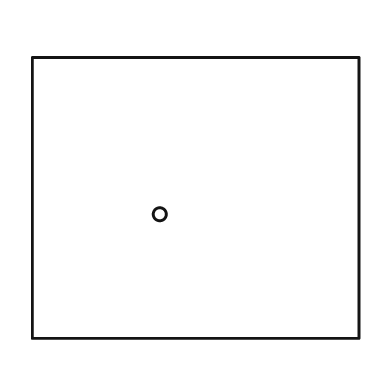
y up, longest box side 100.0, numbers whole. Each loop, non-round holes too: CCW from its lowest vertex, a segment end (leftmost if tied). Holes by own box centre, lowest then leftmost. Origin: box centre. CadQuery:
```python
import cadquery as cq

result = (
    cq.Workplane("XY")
    .moveTo(-50.0, -43.0)
    .lineTo(50.0, -43.0)
    .lineTo(50.0, 43.0)
    .lineTo(-50.0, 43.0)
    .close()
    .moveTo(-11.0, -5.0)
    .circle(2.0)
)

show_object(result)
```